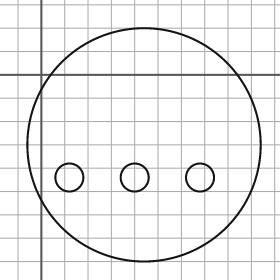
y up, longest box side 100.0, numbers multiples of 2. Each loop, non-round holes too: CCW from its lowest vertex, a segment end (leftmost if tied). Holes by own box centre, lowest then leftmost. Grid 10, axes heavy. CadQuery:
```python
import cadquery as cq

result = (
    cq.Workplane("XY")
    .moveTo(44.0, -30.0)
    .circle(50.0)
    .moveTo(12.0, -44.0)
    .circle(6.0)
    .moveTo(40.0, -44.0)
    .circle(6.0)
    .moveTo(68.0, -44.0)
    .circle(6.0)
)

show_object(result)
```